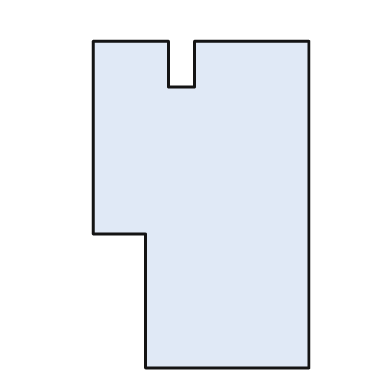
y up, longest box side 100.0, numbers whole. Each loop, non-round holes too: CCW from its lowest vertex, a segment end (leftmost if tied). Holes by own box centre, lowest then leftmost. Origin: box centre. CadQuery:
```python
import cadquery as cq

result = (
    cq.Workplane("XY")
    .moveTo(-17.0, -50.0)
    .lineTo(33.0, -50.0)
    .lineTo(33.0, 50.0)
    .lineTo(-2.0, 50.0)
    .lineTo(-2.0, 36.0)
    .lineTo(-10.0, 36.0)
    .lineTo(-10.0, 50.0)
    .lineTo(-33.0, 50.0)
    .lineTo(-33.0, -9.0)
    .lineTo(-17.0, -9.0)
    .close()
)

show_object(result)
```